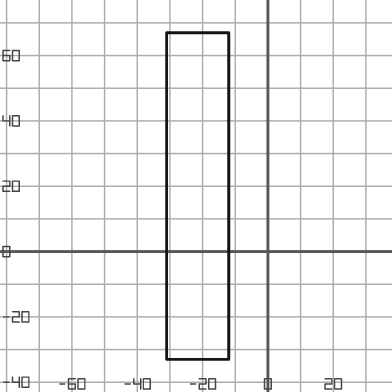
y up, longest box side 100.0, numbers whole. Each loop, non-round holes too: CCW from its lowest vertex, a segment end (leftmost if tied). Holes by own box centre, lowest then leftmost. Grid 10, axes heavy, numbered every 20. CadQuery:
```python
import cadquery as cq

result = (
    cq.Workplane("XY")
    .moveTo(-31.0, -33.0)
    .lineTo(-12.0, -33.0)
    .lineTo(-12.0, 67.0)
    .lineTo(-31.0, 67.0)
    .close()
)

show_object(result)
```